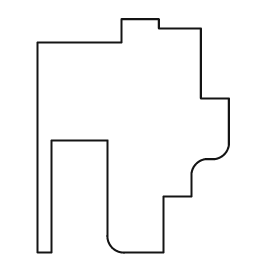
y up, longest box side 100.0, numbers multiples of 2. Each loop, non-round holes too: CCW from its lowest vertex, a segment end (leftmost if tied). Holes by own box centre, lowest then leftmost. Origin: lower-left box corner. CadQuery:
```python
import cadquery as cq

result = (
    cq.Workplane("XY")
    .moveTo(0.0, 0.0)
    .lineTo(6.0, 0.0)
    .lineTo(6.0, 48.0)
    .lineTo(30.0, 48.0)
    .lineTo(30.0, 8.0)
    .threePointArc((32.0, 2.0), (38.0, 0.0))
    .lineTo(54.0, 0.0)
    .lineTo(54.0, 24.0)
    .lineTo(66.0, 24.0)
    .lineTo(66.0, 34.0)
    .threePointArc((68.0, 38.0), (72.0, 40.0))
    .lineTo(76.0, 40.0)
    .threePointArc((80.0, 42.0), (82.0, 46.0))
    .lineTo(82.0, 66.0)
    .lineTo(70.0, 66.0)
    .lineTo(70.0, 96.0)
    .lineTo(52.0, 96.0)
    .lineTo(52.0, 100.0)
    .lineTo(36.0, 100.0)
    .lineTo(36.0, 90.0)
    .lineTo(0.0, 90.0)
    .close()
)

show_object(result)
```